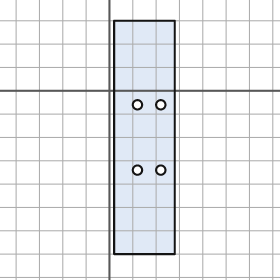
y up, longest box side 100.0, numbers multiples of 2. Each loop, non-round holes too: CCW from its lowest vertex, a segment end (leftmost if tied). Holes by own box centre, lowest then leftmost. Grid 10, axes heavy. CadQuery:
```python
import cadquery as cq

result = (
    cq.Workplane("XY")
    .moveTo(2.0, -70.0)
    .lineTo(28.0, -70.0)
    .lineTo(28.0, 30.0)
    .lineTo(2.0, 30.0)
    .close()
    .moveTo(12.0, -34.0)
    .circle(2.0)
    .moveTo(22.0, -34.0)
    .circle(2.0)
    .moveTo(12.0, -6.0)
    .circle(2.0)
    .moveTo(22.0, -6.0)
    .circle(2.0)
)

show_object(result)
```